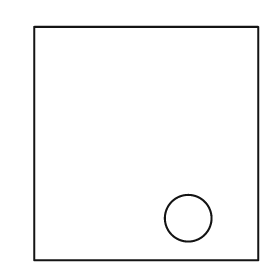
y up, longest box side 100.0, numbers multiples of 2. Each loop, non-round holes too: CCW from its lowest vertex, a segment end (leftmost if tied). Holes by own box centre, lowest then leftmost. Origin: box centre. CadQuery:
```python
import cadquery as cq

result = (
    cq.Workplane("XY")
    .moveTo(-48.0, -50.0)
    .lineTo(48.0, -50.0)
    .lineTo(48.0, 50.0)
    .lineTo(-48.0, 50.0)
    .close()
    .moveTo(18.0, -32.0)
    .circle(10.0)
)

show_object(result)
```